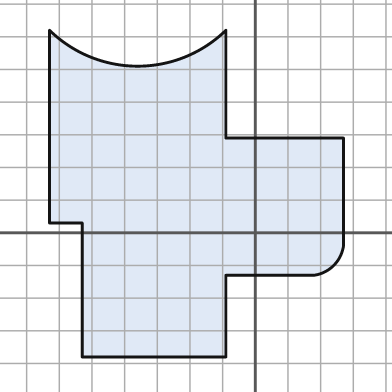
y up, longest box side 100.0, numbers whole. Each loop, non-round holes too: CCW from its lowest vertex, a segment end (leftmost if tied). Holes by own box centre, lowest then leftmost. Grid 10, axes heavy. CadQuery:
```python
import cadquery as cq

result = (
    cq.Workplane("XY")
    .moveTo(-53.0, -38.0)
    .lineTo(-9.0, -38.0)
    .lineTo(-9.0, -13.0)
    .lineTo(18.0, -13.0)
    .threePointArc((24.0, -10.0), (27.0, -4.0))
    .lineTo(27.0, 29.0)
    .lineTo(-9.0, 29.0)
    .lineTo(-9.0, 62.0)
    .threePointArc((-36.0, 51.0), (-63.0, 62.0))
    .lineTo(-63.0, 3.0)
    .lineTo(-53.0, 3.0)
    .close()
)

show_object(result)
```